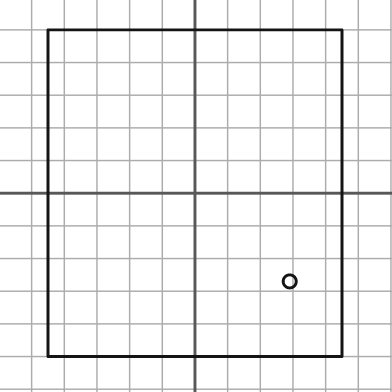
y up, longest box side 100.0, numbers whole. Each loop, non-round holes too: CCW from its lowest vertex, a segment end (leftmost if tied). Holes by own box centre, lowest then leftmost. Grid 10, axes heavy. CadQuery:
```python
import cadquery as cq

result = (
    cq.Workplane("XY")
    .moveTo(-45.0, -50.0)
    .lineTo(45.0, -50.0)
    .lineTo(45.0, 50.0)
    .lineTo(-45.0, 50.0)
    .close()
    .moveTo(29.0, -27.0)
    .circle(2.0)
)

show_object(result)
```